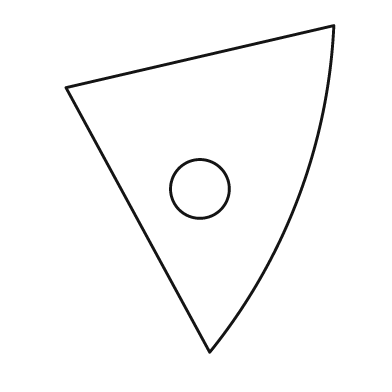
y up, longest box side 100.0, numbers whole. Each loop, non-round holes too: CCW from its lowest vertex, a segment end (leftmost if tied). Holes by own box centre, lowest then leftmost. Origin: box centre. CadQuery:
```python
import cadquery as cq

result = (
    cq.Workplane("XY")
    .moveTo(3.0, -50.0)
    .threePointArc((30.0, -3.0), (41.0, 50.0))
    .lineTo(-41.0, 31.0)
    .close()
    .moveTo(0.0, 0.0)
    .circle(9.0)
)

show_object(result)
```